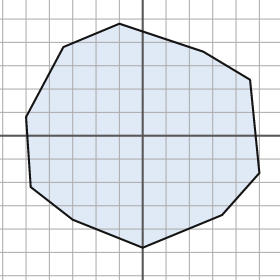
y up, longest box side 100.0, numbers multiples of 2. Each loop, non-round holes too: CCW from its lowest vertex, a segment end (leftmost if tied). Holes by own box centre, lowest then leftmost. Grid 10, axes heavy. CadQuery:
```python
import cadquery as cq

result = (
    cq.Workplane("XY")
    .moveTo(0.0, -48.0)
    .lineTo(34.0, -34.0)
    .lineTo(50.0, -16.0)
    .lineTo(46.0, 24.0)
    .lineTo(26.0, 36.0)
    .lineTo(-10.0, 48.0)
    .lineTo(-34.0, 38.0)
    .lineTo(-50.0, 8.0)
    .lineTo(-48.0, -22.0)
    .lineTo(-30.0, -36.0)
    .close()
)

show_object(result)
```